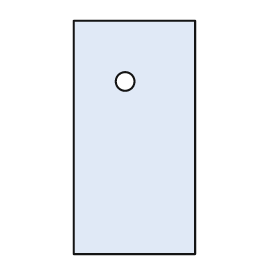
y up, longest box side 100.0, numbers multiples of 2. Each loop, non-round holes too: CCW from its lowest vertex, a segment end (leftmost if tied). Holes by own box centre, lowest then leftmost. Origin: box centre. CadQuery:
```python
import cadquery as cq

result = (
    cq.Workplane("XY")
    .moveTo(-26.0, -50.0)
    .lineTo(26.0, -50.0)
    .lineTo(26.0, 50.0)
    .lineTo(-26.0, 50.0)
    .close()
    .moveTo(-4.0, 24.0)
    .circle(4.0)
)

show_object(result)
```